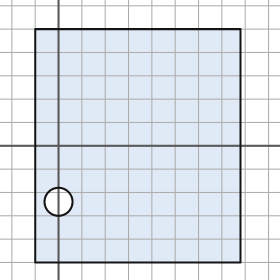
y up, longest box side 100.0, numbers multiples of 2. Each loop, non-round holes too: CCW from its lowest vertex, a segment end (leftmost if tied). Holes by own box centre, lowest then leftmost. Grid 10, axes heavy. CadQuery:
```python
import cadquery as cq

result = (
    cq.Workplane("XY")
    .moveTo(-10.0, -50.0)
    .lineTo(78.0, -50.0)
    .lineTo(78.0, 50.0)
    .lineTo(-10.0, 50.0)
    .close()
    .moveTo(0.0, -24.0)
    .circle(6.0)
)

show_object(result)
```